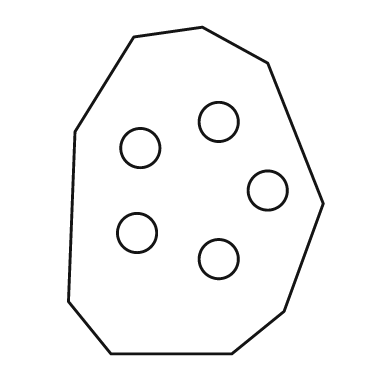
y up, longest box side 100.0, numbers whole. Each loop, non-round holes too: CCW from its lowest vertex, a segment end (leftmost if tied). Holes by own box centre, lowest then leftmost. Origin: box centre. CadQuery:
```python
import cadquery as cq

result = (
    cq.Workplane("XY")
    .moveTo(-26.0, -50.0)
    .lineTo(11.0, -50.0)
    .lineTo(27.0, -37.0)
    .lineTo(39.0, -4.0)
    .lineTo(22.0, 39.0)
    .lineTo(2.0, 50.0)
    .lineTo(-19.0, 47.0)
    .lineTo(-37.0, 18.0)
    .lineTo(-39.0, -34.0)
    .close()
    .moveTo(7.0, -21.0)
    .circle(6.0)
    .moveTo(-18.0, -13.0)
    .circle(6.0)
    .moveTo(22.0, 0.0)
    .circle(6.0)
    .moveTo(-17.0, 13.0)
    .circle(6.0)
    .moveTo(7.0, 21.0)
    .circle(6.0)
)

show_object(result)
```